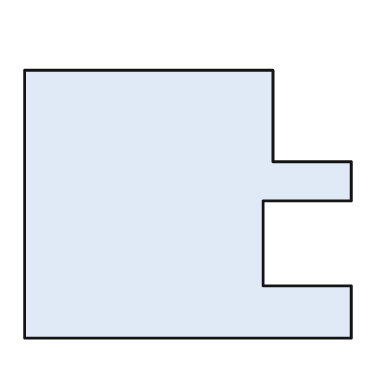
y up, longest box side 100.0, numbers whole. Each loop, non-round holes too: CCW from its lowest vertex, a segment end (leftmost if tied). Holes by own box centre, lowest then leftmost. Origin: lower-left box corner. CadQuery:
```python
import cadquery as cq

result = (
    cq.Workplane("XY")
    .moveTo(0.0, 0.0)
    .lineTo(100.0, 0.0)
    .lineTo(100.0, 16.0)
    .lineTo(73.0, 16.0)
    .lineTo(73.0, 42.0)
    .lineTo(100.0, 42.0)
    .lineTo(100.0, 54.0)
    .lineTo(76.0, 54.0)
    .lineTo(76.0, 82.0)
    .lineTo(0.0, 82.0)
    .close()
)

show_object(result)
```